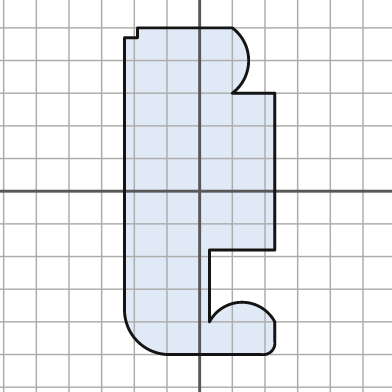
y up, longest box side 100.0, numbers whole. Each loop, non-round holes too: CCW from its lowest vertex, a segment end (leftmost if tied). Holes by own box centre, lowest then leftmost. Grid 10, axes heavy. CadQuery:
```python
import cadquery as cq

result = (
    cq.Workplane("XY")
    .moveTo(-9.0, -50.0)
    .lineTo(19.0, -50.0)
    .threePointArc((22.0, -49.0), (23.0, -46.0))
    .lineTo(23.0, -40.0)
    .threePointArc((13.0, -34.0), (3.0, -40.0))
    .lineTo(3.0, -18.0)
    .lineTo(23.0, -18.0)
    .lineTo(23.0, 30.0)
    .lineTo(10.0, 30.0)
    .threePointArc((15.0, 40.0), (10.0, 50.0))
    .lineTo(-19.0, 50.0)
    .lineTo(-19.0, 47.0)
    .lineTo(-23.0, 47.0)
    .lineTo(-23.0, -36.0)
    .threePointArc((-19.0, -46.0), (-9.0, -50.0))
    .close()
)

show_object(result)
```